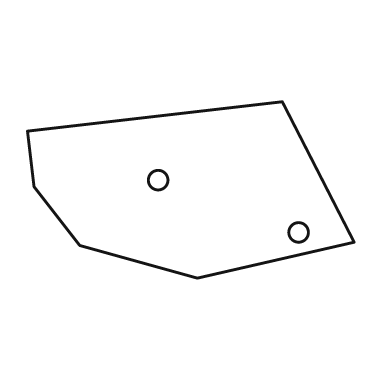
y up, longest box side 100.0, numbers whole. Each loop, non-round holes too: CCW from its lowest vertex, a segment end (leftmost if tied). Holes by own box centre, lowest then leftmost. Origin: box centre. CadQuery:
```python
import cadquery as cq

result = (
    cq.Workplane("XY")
    .moveTo(2.0, -27.0)
    .lineTo(50.0, -16.0)
    .lineTo(28.0, 27.0)
    .lineTo(-50.0, 18.0)
    .lineTo(-48.0, 1.0)
    .lineTo(-34.0, -17.0)
    .close()
    .moveTo(33.0, -13.0)
    .circle(3.0)
    .moveTo(-10.0, 3.0)
    .circle(3.0)
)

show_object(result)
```